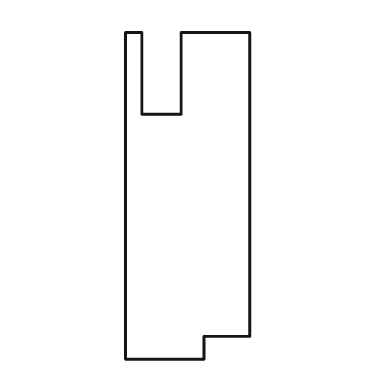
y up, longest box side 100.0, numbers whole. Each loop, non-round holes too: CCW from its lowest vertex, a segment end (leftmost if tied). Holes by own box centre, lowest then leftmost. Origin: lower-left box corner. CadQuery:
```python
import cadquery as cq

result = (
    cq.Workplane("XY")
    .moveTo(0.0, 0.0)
    .lineTo(24.0, 0.0)
    .lineTo(24.0, 7.0)
    .lineTo(38.0, 7.0)
    .lineTo(38.0, 100.0)
    .lineTo(17.0, 100.0)
    .lineTo(17.0, 75.0)
    .lineTo(5.0, 75.0)
    .lineTo(5.0, 100.0)
    .lineTo(0.0, 100.0)
    .close()
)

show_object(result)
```